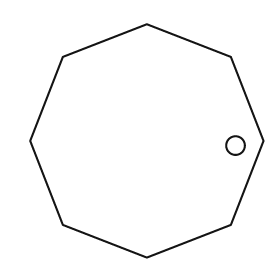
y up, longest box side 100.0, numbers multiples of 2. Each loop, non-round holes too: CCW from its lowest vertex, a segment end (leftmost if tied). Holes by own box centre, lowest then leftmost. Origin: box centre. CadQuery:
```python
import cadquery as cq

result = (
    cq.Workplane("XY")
    .moveTo(0.0, -50.0)
    .lineTo(36.0, -36.0)
    .lineTo(50.0, 0.0)
    .lineTo(36.0, 36.0)
    .lineTo(0.0, 50.0)
    .lineTo(-36.0, 36.0)
    .lineTo(-50.0, 0.0)
    .lineTo(-36.0, -36.0)
    .close()
    .moveTo(38.0, -2.0)
    .circle(4.0)
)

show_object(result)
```